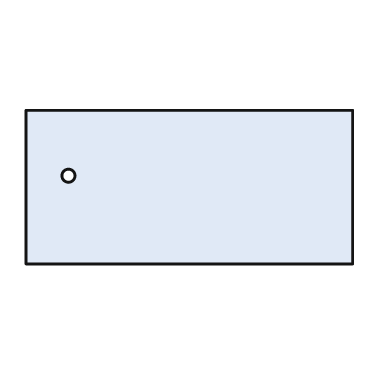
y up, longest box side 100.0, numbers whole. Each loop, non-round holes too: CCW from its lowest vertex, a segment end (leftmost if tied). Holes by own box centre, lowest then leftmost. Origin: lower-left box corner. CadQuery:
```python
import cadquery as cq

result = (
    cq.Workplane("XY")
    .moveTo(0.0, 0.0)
    .lineTo(100.0, 0.0)
    .lineTo(100.0, 47.0)
    .lineTo(0.0, 47.0)
    .close()
    .moveTo(13.0, 27.0)
    .circle(2.0)
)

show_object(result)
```